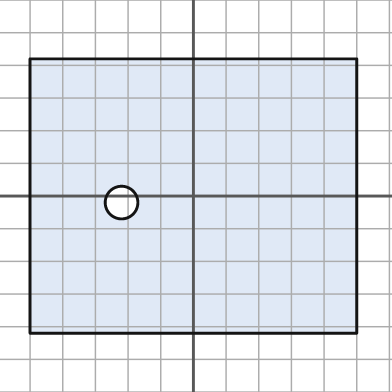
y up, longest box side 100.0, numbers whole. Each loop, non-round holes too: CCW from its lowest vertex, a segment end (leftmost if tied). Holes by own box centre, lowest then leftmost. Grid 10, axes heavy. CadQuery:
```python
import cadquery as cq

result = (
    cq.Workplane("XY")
    .moveTo(-50.0, -42.0)
    .lineTo(50.0, -42.0)
    .lineTo(50.0, 42.0)
    .lineTo(-50.0, 42.0)
    .close()
    .moveTo(-22.0, -2.0)
    .circle(5.0)
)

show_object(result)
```